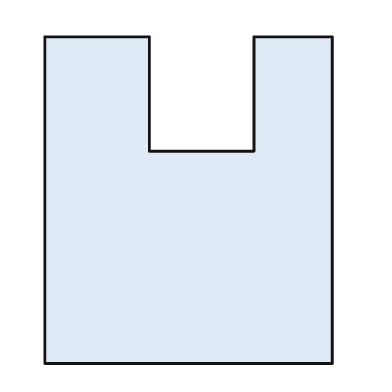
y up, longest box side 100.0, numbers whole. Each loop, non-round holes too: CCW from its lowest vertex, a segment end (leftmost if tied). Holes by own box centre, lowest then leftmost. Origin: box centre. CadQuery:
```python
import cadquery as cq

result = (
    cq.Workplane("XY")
    .moveTo(-44.0, -50.0)
    .lineTo(44.0, -50.0)
    .lineTo(44.0, 50.0)
    .lineTo(20.0, 50.0)
    .lineTo(20.0, 15.0)
    .lineTo(-12.0, 15.0)
    .lineTo(-12.0, 50.0)
    .lineTo(-44.0, 50.0)
    .close()
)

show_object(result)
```